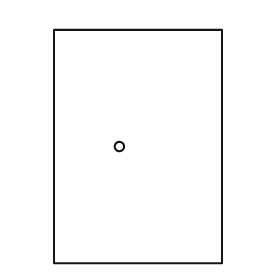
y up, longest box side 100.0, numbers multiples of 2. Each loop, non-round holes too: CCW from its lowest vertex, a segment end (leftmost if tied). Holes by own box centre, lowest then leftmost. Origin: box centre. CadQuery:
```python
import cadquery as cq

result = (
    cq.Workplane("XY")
    .moveTo(-36.0, -50.0)
    .lineTo(36.0, -50.0)
    .lineTo(36.0, 50.0)
    .lineTo(-36.0, 50.0)
    .close()
    .moveTo(-8.0, 0.0)
    .circle(2.0)
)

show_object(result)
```